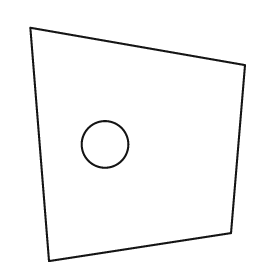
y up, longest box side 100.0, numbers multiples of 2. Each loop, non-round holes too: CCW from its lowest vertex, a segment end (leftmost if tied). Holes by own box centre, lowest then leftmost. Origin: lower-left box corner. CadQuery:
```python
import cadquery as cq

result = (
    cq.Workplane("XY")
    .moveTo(8.0, 0.0)
    .lineTo(86.0, 12.0)
    .lineTo(92.0, 84.0)
    .lineTo(0.0, 100.0)
    .close()
    .moveTo(32.0, 50.0)
    .circle(10.0)
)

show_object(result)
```